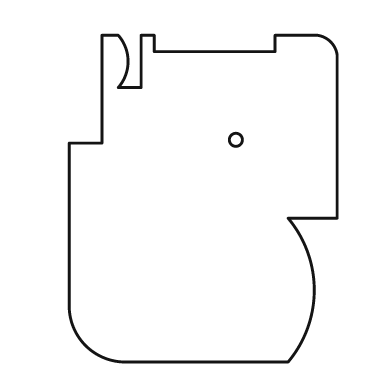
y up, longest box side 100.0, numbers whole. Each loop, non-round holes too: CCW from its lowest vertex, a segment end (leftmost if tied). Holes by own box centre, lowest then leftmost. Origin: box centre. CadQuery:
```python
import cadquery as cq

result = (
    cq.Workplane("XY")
    .moveTo(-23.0, -50.0)
    .lineTo(26.0, -50.0)
    .threePointArc((34.0, -28.0), (26.0, -6.0))
    .lineTo(41.0, -6.0)
    .lineTo(41.0, 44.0)
    .threePointArc((39.0, 48.0), (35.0, 50.0))
    .lineTo(22.0, 50.0)
    .lineTo(22.0, 45.0)
    .lineTo(-15.0, 45.0)
    .lineTo(-15.0, 50.0)
    .lineTo(-19.0, 50.0)
    .lineTo(-19.0, 34.0)
    .lineTo(-26.0, 34.0)
    .threePointArc((-23.0, 42.0), (-26.0, 50.0))
    .lineTo(-31.0, 50.0)
    .lineTo(-31.0, 17.0)
    .lineTo(-41.0, 17.0)
    .lineTo(-41.0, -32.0)
    .threePointArc((-36.0, -45.0), (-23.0, -50.0))
    .close()
    .moveTo(10.0, 18.0)
    .circle(2.0)
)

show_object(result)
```